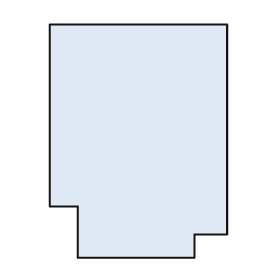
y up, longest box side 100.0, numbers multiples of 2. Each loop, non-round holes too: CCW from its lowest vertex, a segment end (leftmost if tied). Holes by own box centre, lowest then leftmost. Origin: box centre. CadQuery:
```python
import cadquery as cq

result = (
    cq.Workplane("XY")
    .moveTo(-26.0, -50.0)
    .lineTo(24.0, -50.0)
    .lineTo(24.0, -40.0)
    .lineTo(38.0, -40.0)
    .lineTo(38.0, 50.0)
    .lineTo(-38.0, 50.0)
    .lineTo(-38.0, -28.0)
    .lineTo(-26.0, -28.0)
    .close()
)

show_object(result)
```